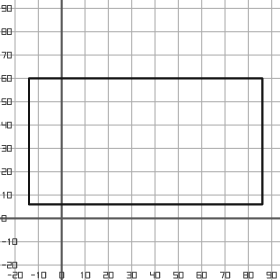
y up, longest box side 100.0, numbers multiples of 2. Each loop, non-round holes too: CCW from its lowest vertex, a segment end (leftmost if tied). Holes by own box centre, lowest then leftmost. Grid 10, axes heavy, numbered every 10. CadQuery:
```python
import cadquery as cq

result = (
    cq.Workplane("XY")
    .moveTo(-14.0, 6.0)
    .lineTo(86.0, 6.0)
    .lineTo(86.0, 60.0)
    .lineTo(-14.0, 60.0)
    .close()
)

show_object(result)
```